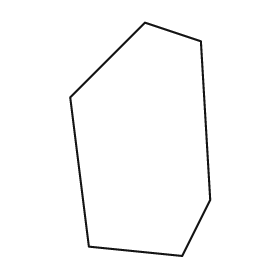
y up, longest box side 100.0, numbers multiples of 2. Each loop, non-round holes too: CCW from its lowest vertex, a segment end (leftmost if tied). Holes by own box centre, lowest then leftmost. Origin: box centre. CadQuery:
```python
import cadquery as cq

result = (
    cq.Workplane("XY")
    .moveTo(18.0, -50.0)
    .lineTo(30.0, -26.0)
    .lineTo(26.0, 42.0)
    .lineTo(2.0, 50.0)
    .lineTo(-30.0, 18.0)
    .lineTo(-22.0, -46.0)
    .close()
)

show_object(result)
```